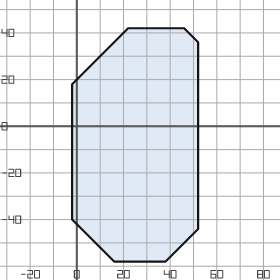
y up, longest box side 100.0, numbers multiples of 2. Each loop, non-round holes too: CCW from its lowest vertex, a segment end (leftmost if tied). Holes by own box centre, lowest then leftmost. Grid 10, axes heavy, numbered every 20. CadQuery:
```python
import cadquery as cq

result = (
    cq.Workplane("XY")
    .moveTo(16.0, -58.0)
    .lineTo(38.0, -58.0)
    .lineTo(52.0, -44.0)
    .lineTo(52.0, 36.0)
    .lineTo(46.0, 42.0)
    .lineTo(22.0, 42.0)
    .lineTo(-2.0, 18.0)
    .lineTo(-2.0, -40.0)
    .close()
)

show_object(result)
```